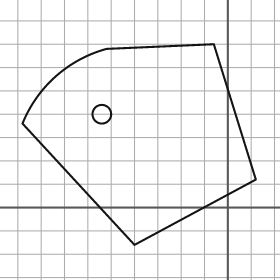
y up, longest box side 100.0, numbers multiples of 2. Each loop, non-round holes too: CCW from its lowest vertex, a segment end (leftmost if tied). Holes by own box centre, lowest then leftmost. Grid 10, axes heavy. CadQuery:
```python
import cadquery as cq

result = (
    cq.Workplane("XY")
    .moveTo(-40.0, -16.0)
    .lineTo(12.0, 12.0)
    .lineTo(-6.0, 70.0)
    .lineTo(-52.0, 68.0)
    .threePointArc((-74.0, 56.0), (-88.0, 36.0))
    .close()
    .moveTo(-54.0, 40.0)
    .circle(4.0)
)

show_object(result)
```